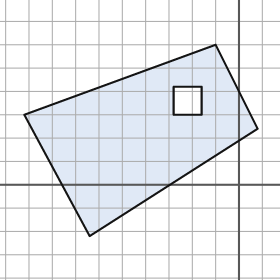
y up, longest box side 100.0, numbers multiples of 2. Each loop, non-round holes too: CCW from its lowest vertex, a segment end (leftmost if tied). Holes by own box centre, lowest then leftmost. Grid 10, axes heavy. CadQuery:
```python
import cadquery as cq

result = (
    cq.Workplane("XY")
    .moveTo(-64.0, -22.0)
    .lineTo(8.0, 24.0)
    .lineTo(-10.0, 60.0)
    .lineTo(-92.0, 30.0)
    .close()
    .moveTo(-28.0, 30.0)
    .lineTo(-16.0, 30.0)
    .lineTo(-16.0, 42.0)
    .lineTo(-28.0, 42.0)
    .close()
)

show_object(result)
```